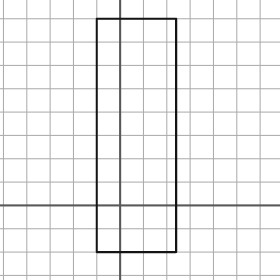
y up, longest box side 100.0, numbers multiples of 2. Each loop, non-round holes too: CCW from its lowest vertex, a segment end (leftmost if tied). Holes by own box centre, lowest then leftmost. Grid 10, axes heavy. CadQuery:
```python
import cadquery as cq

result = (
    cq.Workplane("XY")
    .moveTo(-10.0, -20.0)
    .lineTo(24.0, -20.0)
    .lineTo(24.0, 80.0)
    .lineTo(-10.0, 80.0)
    .close()
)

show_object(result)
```